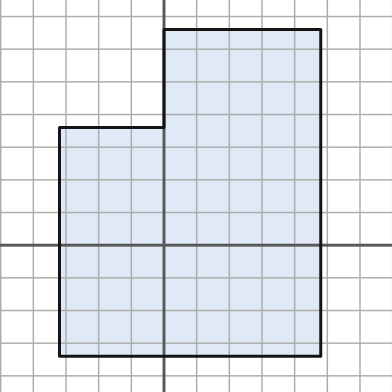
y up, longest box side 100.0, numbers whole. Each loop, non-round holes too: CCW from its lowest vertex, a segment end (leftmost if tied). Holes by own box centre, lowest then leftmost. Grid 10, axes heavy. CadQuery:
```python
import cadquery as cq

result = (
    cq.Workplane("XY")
    .moveTo(-32.0, -34.0)
    .lineTo(48.0, -34.0)
    .lineTo(48.0, 66.0)
    .lineTo(0.0, 66.0)
    .lineTo(0.0, 36.0)
    .lineTo(-32.0, 36.0)
    .close()
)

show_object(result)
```